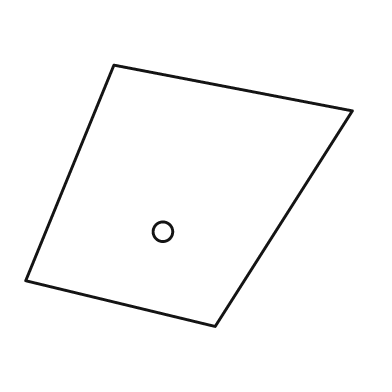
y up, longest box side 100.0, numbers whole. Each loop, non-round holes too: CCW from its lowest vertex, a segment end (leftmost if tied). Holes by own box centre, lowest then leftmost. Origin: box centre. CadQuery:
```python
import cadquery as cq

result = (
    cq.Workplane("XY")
    .moveTo(8.0, -40.0)
    .lineTo(50.0, 26.0)
    .lineTo(-23.0, 40.0)
    .lineTo(-50.0, -26.0)
    .close()
    .moveTo(-8.0, -11.0)
    .circle(3.0)
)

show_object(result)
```